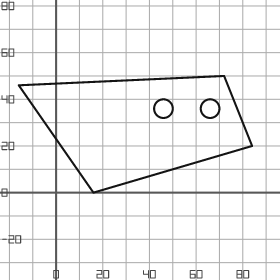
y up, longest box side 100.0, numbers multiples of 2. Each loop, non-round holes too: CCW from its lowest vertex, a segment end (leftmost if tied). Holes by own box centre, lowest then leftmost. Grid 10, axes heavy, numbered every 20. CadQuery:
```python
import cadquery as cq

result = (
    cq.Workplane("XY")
    .moveTo(16.0, 0.0)
    .lineTo(84.0, 20.0)
    .lineTo(72.0, 50.0)
    .lineTo(-16.0, 46.0)
    .close()
    .moveTo(46.0, 36.0)
    .circle(4.0)
    .moveTo(66.0, 36.0)
    .circle(4.0)
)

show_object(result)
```